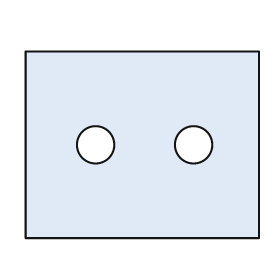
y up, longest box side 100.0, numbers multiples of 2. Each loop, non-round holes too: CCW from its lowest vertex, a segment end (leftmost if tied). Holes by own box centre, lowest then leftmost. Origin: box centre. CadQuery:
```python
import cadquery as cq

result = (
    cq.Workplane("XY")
    .moveTo(-50.0, -40.0)
    .lineTo(50.0, -40.0)
    .lineTo(50.0, 40.0)
    .lineTo(-50.0, 40.0)
    .close()
    .moveTo(-20.0, 0.0)
    .circle(8.0)
    .moveTo(22.0, 0.0)
    .circle(8.0)
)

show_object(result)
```